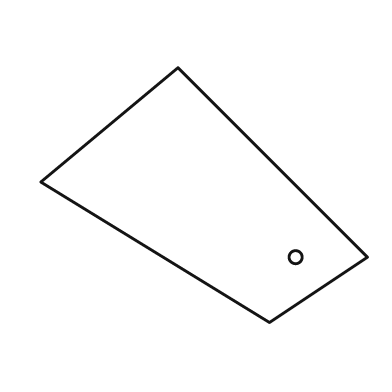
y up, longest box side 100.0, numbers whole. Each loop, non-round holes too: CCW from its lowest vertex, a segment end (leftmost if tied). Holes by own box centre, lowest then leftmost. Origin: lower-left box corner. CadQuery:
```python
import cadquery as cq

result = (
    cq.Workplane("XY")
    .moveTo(70.0, 0.0)
    .lineTo(100.0, 20.0)
    .lineTo(42.0, 78.0)
    .lineTo(0.0, 43.0)
    .close()
    .moveTo(78.0, 20.0)
    .circle(2.0)
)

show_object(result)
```